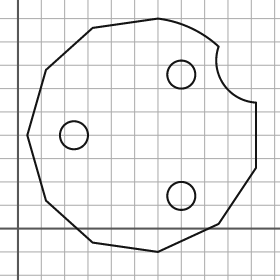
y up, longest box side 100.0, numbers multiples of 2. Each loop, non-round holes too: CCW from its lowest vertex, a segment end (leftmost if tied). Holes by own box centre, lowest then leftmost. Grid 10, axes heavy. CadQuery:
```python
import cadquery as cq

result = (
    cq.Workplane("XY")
    .moveTo(60.0, -10.0)
    .lineTo(86.0, 2.0)
    .lineTo(102.0, 26.0)
    .lineTo(102.0, 54.0)
    .threePointArc((88.0, 62.0), (86.0, 78.0))
    .threePointArc((74.0, 86.0), (60.0, 90.0))
    .lineTo(32.0, 86.0)
    .lineTo(12.0, 68.0)
    .lineTo(4.0, 40.0)
    .lineTo(12.0, 12.0)
    .lineTo(32.0, -6.0)
    .close()
    .moveTo(70.0, 14.0)
    .circle(6.0)
    .moveTo(24.0, 40.0)
    .circle(6.0)
    .moveTo(70.0, 66.0)
    .circle(6.0)
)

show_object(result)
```